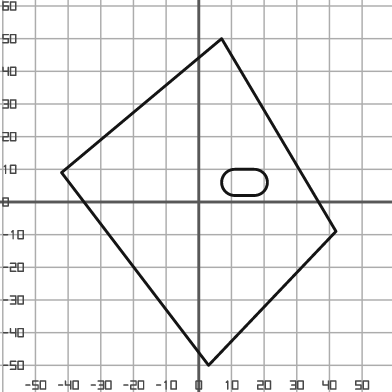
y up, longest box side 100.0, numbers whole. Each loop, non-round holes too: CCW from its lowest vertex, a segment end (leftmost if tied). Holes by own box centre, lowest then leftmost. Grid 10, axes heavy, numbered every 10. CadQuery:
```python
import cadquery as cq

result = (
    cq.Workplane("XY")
    .moveTo(3.0, -50.0)
    .lineTo(42.0, -9.0)
    .lineTo(7.0, 50.0)
    .lineTo(-42.0, 9.0)
    .close()
    .moveTo(11.0, 2.0)
    .lineTo(17.0, 2.0)
    .threePointArc((21.0, 6.0), (17.0, 10.0))
    .lineTo(11.0, 10.0)
    .threePointArc((7.0, 6.0), (11.0, 2.0))
    .close()
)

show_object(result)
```